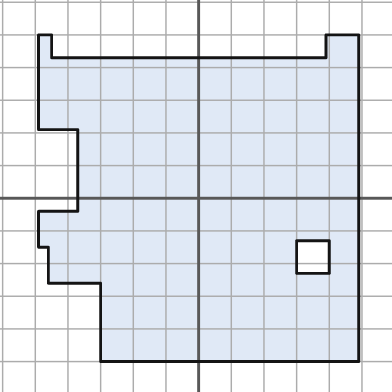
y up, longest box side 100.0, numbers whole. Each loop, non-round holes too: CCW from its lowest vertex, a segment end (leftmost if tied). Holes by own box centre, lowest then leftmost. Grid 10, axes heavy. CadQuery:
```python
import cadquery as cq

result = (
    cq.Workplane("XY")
    .moveTo(-30.0, -50.0)
    .lineTo(49.0, -50.0)
    .lineTo(49.0, 50.0)
    .lineTo(39.0, 50.0)
    .lineTo(39.0, 43.0)
    .lineTo(-45.0, 43.0)
    .lineTo(-45.0, 50.0)
    .lineTo(-49.0, 50.0)
    .lineTo(-49.0, 21.0)
    .lineTo(-37.0, 21.0)
    .lineTo(-37.0, -4.0)
    .lineTo(-49.0, -4.0)
    .lineTo(-49.0, -15.0)
    .lineTo(-46.0, -15.0)
    .lineTo(-46.0, -26.0)
    .lineTo(-30.0, -26.0)
    .close()
    .moveTo(30.0, -23.0)
    .lineTo(40.0, -23.0)
    .lineTo(40.0, -13.0)
    .lineTo(30.0, -13.0)
    .close()
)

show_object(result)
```